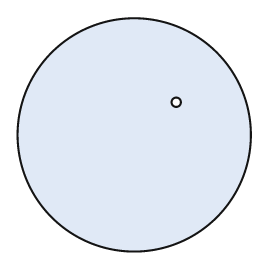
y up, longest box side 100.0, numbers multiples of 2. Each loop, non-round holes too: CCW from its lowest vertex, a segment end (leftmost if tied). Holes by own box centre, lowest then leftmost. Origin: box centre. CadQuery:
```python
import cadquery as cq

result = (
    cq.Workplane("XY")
    .moveTo(0.0, 0.0)
    .circle(50.0)
    .moveTo(18.0, 14.0)
    .circle(2.0)
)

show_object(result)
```